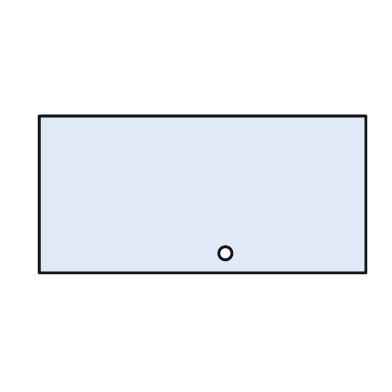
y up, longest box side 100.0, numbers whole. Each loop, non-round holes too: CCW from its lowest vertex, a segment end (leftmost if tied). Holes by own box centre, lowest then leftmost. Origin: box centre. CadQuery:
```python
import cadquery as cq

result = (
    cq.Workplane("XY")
    .moveTo(-50.0, -24.0)
    .lineTo(50.0, -24.0)
    .lineTo(50.0, 24.0)
    .lineTo(-50.0, 24.0)
    .close()
    .moveTo(7.0, -18.0)
    .circle(2.0)
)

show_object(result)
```